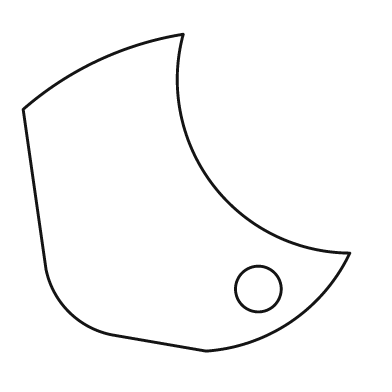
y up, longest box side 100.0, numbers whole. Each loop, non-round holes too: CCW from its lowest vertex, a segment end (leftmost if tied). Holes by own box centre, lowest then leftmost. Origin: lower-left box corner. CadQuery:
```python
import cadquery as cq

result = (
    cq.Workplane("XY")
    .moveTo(56.0, 0.0)
    .threePointArc((82.0, 9.0), (100.0, 30.0))
    .threePointArc((58.0, 51.0), (49.0, 97.0))
    .threePointArc((23.0, 89.0), (0.0, 74.0))
    .lineTo(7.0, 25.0)
    .threePointArc((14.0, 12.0), (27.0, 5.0))
    .close()
    .moveTo(72.0, 19.0)
    .circle(7.0)
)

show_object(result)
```